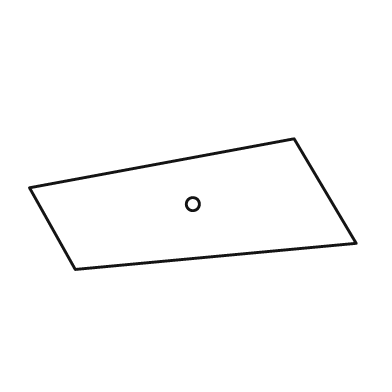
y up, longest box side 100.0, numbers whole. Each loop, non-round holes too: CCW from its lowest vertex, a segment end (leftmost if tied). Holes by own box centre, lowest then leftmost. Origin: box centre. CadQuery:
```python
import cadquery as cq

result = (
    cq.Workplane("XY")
    .moveTo(-36.0, -20.0)
    .lineTo(50.0, -12.0)
    .lineTo(31.0, 20.0)
    .lineTo(-50.0, 5.0)
    .close()
    .moveTo(0.0, 0.0)
    .circle(2.0)
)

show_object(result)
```